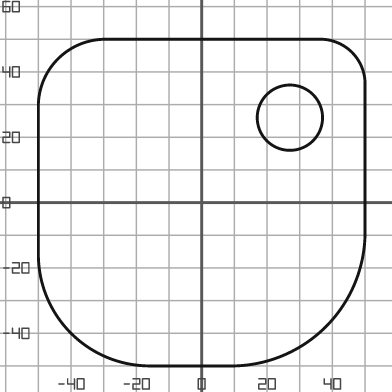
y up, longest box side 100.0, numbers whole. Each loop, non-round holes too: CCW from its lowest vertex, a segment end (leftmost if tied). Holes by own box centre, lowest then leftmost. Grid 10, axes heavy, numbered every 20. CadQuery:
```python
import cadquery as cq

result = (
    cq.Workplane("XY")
    .moveTo(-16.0, -50.0)
    .lineTo(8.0, -50.0)
    .threePointArc((38.0, -38.0), (50.0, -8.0))
    .lineTo(50.0, 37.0)
    .threePointArc((46.0, 46.0), (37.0, 50.0))
    .lineTo(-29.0, 50.0)
    .threePointArc((-44.0, 44.0), (-50.0, 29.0))
    .lineTo(-50.0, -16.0)
    .threePointArc((-40.0, -40.0), (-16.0, -50.0))
    .close()
    .moveTo(27.0, 26.0)
    .circle(10.0)
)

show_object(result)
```